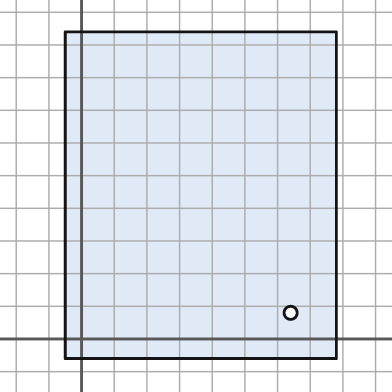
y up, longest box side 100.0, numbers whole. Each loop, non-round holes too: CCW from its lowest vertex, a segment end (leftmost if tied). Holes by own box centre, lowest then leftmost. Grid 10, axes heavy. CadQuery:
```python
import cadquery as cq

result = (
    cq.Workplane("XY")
    .moveTo(-5.0, -6.0)
    .lineTo(78.0, -6.0)
    .lineTo(78.0, 94.0)
    .lineTo(-5.0, 94.0)
    .close()
    .moveTo(64.0, 8.0)
    .circle(2.0)
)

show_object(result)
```